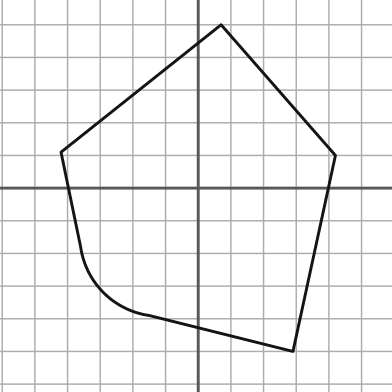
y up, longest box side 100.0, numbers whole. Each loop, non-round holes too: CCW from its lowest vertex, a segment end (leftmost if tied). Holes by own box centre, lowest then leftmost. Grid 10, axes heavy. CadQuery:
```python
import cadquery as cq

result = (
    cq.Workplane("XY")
    .moveTo(29.0, -50.0)
    .lineTo(42.0, 10.0)
    .lineTo(7.0, 50.0)
    .lineTo(-42.0, 11.0)
    .lineTo(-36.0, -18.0)
    .threePointArc((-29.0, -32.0), (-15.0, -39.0))
    .close()
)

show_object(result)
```